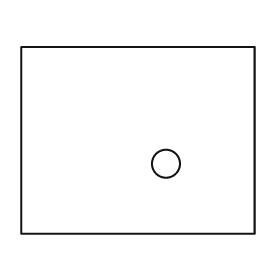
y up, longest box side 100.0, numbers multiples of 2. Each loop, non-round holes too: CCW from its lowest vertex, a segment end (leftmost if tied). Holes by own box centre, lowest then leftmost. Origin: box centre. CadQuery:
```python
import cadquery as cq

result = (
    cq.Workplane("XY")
    .moveTo(-50.0, -40.0)
    .lineTo(50.0, -40.0)
    .lineTo(50.0, 40.0)
    .lineTo(-50.0, 40.0)
    .close()
    .moveTo(12.0, -10.0)
    .circle(6.0)
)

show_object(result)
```